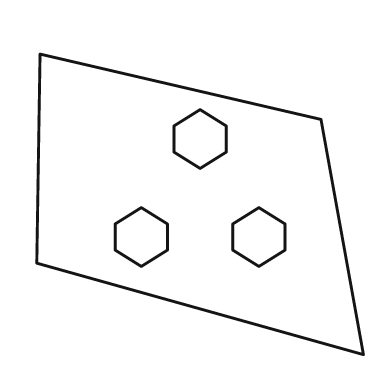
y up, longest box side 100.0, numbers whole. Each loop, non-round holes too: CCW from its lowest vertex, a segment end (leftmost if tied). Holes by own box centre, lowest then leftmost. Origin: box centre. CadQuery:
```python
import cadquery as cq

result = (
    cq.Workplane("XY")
    .moveTo(50.0, -46.0)
    .lineTo(37.0, 26.0)
    .lineTo(-49.0, 46.0)
    .lineTo(-50.0, -18.0)
    .close()
    .moveTo(-18.0, -19.0)
    .lineTo(-10.0, -14.0)
    .lineTo(-10.0, -6.0)
    .lineTo(-18.0, -1.0)
    .lineTo(-26.0, -6.0)
    .lineTo(-26.0, -14.0)
    .close()
    .moveTo(18.0, -19.0)
    .lineTo(26.0, -14.0)
    .lineTo(26.0, -6.0)
    .lineTo(18.0, -1.0)
    .lineTo(10.0, -6.0)
    .lineTo(10.0, -14.0)
    .close()
    .moveTo(0.0, 11.0)
    .lineTo(8.0, 16.0)
    .lineTo(8.0, 24.0)
    .lineTo(0.0, 29.0)
    .lineTo(-8.0, 24.0)
    .lineTo(-8.0, 16.0)
    .close()
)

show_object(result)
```